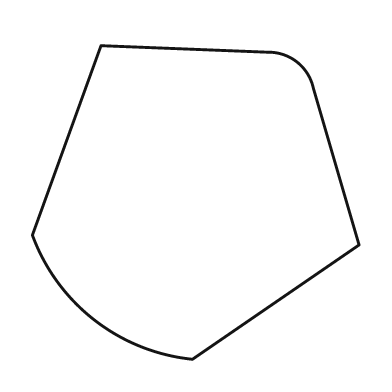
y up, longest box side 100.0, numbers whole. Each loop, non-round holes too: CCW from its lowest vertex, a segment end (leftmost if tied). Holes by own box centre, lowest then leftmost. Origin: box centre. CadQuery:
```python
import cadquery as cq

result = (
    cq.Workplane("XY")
    .moveTo(-1.0, -48.0)
    .lineTo(50.0, -13.0)
    .lineTo(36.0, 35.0)
    .threePointArc((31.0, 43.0), (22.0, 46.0))
    .lineTo(-29.0, 48.0)
    .lineTo(-50.0, -10.0)
    .threePointArc((-31.0, -36.0), (-1.0, -48.0))
    .close()
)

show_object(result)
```